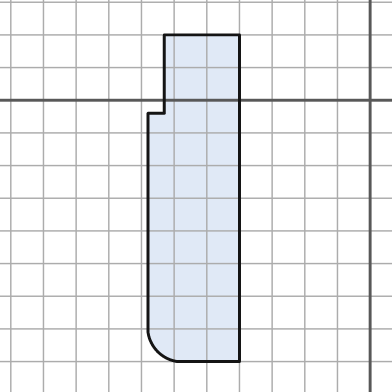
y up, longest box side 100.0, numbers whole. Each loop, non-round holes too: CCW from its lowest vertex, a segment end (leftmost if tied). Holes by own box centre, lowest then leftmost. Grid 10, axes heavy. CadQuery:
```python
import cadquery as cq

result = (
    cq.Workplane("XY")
    .moveTo(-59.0, -80.0)
    .lineTo(-40.0, -80.0)
    .lineTo(-40.0, 20.0)
    .lineTo(-63.0, 20.0)
    .lineTo(-63.0, -4.0)
    .lineTo(-68.0, -4.0)
    .lineTo(-68.0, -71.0)
    .threePointArc((-65.0, -77.0), (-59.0, -80.0))
    .close()
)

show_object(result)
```